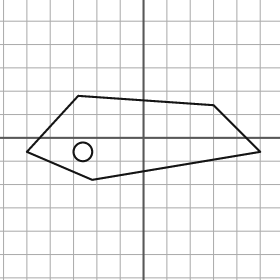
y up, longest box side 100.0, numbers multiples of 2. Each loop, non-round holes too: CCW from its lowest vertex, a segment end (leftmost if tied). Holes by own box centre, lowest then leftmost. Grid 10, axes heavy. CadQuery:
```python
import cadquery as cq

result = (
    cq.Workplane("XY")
    .moveTo(-22.0, -18.0)
    .lineTo(50.0, -6.0)
    .lineTo(30.0, 14.0)
    .lineTo(-28.0, 18.0)
    .lineTo(-50.0, -6.0)
    .close()
    .moveTo(-26.0, -6.0)
    .circle(4.0)
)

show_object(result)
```